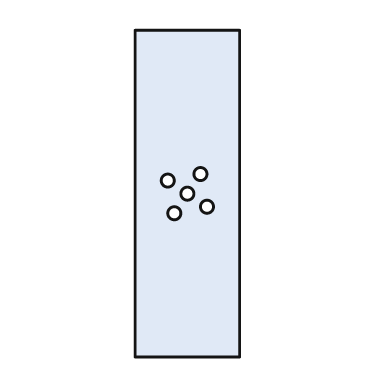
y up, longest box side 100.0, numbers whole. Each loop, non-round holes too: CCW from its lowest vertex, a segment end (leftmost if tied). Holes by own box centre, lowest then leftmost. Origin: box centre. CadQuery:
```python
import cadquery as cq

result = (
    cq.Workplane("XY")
    .moveTo(-16.0, -50.0)
    .lineTo(16.0, -50.0)
    .lineTo(16.0, 50.0)
    .lineTo(-16.0, 50.0)
    .close()
    .moveTo(-4.0, -6.0)
    .circle(2.0)
    .moveTo(6.0, -4.0)
    .circle(2.0)
    .moveTo(0.0, 0.0)
    .circle(2.0)
    .moveTo(-6.0, 4.0)
    .circle(2.0)
    .moveTo(4.0, 6.0)
    .circle(2.0)
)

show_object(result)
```